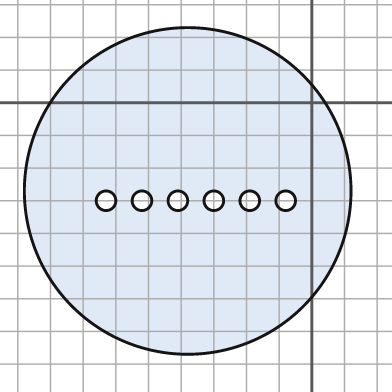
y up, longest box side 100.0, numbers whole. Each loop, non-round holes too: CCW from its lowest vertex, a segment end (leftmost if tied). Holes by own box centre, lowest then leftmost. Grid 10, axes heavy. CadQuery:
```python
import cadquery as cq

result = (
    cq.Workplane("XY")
    .moveTo(-38.0, -27.0)
    .circle(50.0)
    .moveTo(-63.0, -30.0)
    .circle(3.0)
    .moveTo(-52.0, -30.0)
    .circle(3.0)
    .moveTo(-41.0, -30.0)
    .circle(3.0)
    .moveTo(-30.0, -30.0)
    .circle(3.0)
    .moveTo(-19.0, -30.0)
    .circle(3.0)
    .moveTo(-8.0, -30.0)
    .circle(3.0)
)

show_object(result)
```